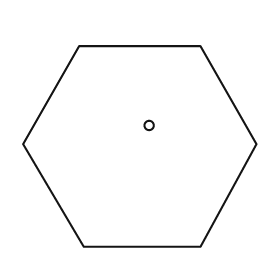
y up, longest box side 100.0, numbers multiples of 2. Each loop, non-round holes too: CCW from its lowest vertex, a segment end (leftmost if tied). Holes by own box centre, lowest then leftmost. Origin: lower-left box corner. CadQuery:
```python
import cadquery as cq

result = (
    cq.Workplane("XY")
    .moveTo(26.0, 0.0)
    .lineTo(76.0, 0.0)
    .lineTo(100.0, 44.0)
    .lineTo(76.0, 86.0)
    .lineTo(24.0, 86.0)
    .lineTo(0.0, 44.0)
    .close()
    .moveTo(54.0, 52.0)
    .circle(2.0)
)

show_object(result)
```